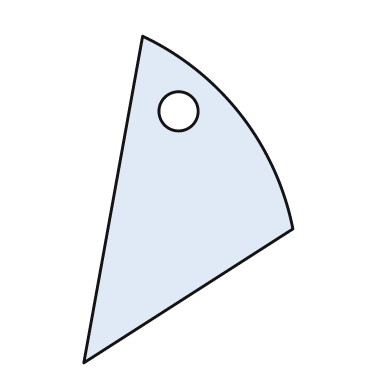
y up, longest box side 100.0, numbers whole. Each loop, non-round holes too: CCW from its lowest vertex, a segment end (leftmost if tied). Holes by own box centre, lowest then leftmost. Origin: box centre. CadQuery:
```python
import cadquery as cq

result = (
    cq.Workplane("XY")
    .moveTo(-32.0, -50.0)
    .lineTo(32.0, -9.0)
    .threePointArc((16.0, 26.0), (-14.0, 50.0))
    .close()
    .moveTo(-3.0, 27.0)
    .circle(6.0)
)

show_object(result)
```